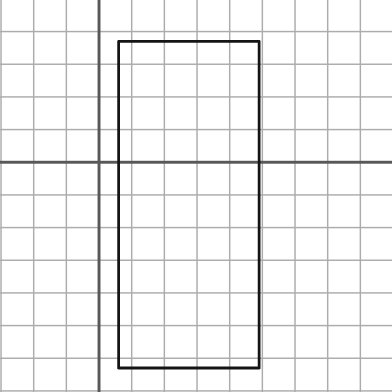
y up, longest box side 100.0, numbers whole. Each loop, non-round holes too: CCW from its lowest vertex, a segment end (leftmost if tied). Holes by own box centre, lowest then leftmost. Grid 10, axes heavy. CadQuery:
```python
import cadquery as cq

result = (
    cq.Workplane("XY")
    .moveTo(6.0, -63.0)
    .lineTo(49.0, -63.0)
    .lineTo(49.0, 37.0)
    .lineTo(6.0, 37.0)
    .close()
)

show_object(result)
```